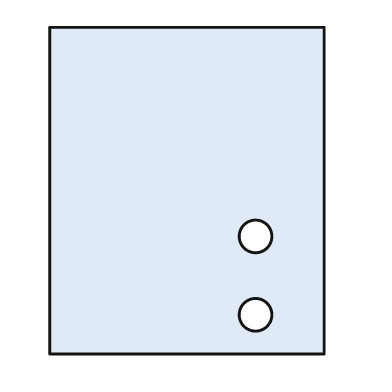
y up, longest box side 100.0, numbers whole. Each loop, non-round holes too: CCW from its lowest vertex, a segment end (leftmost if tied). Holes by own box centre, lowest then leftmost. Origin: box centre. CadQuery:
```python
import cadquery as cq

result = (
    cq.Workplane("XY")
    .moveTo(-42.0, -50.0)
    .lineTo(42.0, -50.0)
    .lineTo(42.0, 50.0)
    .lineTo(-42.0, 50.0)
    .close()
    .moveTo(21.0, -38.0)
    .circle(5.0)
    .moveTo(21.0, -14.0)
    .circle(5.0)
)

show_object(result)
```